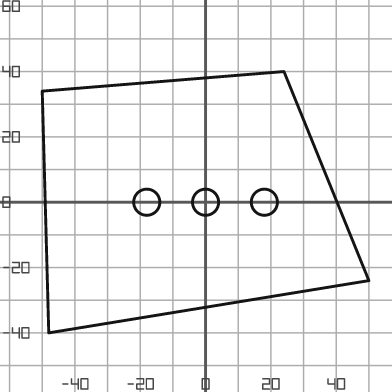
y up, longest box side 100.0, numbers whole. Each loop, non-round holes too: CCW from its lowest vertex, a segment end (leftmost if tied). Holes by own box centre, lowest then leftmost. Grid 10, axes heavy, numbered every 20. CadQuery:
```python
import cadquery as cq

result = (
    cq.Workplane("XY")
    .moveTo(-48.0, -40.0)
    .lineTo(50.0, -24.0)
    .lineTo(24.0, 40.0)
    .lineTo(-50.0, 34.0)
    .close()
    .moveTo(-18.0, 0.0)
    .circle(4.0)
    .moveTo(0.0, 0.0)
    .circle(4.0)
    .moveTo(18.0, 0.0)
    .circle(4.0)
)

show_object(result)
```